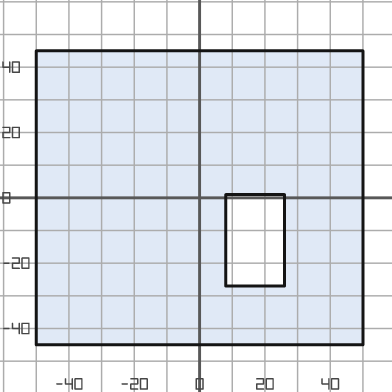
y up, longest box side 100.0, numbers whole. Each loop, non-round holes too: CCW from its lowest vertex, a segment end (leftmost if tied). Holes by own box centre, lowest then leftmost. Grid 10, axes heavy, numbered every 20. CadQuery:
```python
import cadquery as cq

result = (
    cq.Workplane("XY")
    .moveTo(-50.0, -45.0)
    .lineTo(50.0, -45.0)
    .lineTo(50.0, 45.0)
    .lineTo(-50.0, 45.0)
    .close()
    .moveTo(8.0, -27.0)
    .lineTo(26.0, -27.0)
    .lineTo(26.0, 1.0)
    .lineTo(8.0, 1.0)
    .close()
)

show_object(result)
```